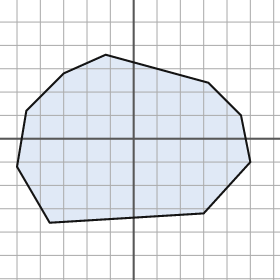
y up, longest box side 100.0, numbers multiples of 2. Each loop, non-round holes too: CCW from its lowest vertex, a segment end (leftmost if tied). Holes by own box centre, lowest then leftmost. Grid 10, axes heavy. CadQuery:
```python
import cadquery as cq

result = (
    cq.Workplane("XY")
    .moveTo(-36.0, -36.0)
    .lineTo(30.0, -32.0)
    .lineTo(50.0, -10.0)
    .lineTo(46.0, 10.0)
    .lineTo(32.0, 24.0)
    .lineTo(-12.0, 36.0)
    .lineTo(-30.0, 28.0)
    .lineTo(-46.0, 12.0)
    .lineTo(-50.0, -12.0)
    .close()
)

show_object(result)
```